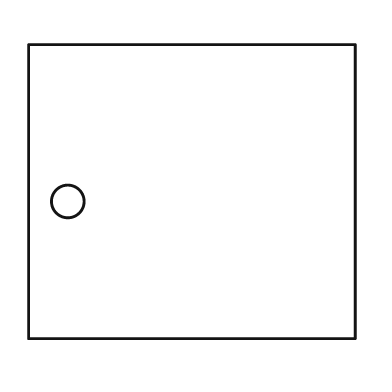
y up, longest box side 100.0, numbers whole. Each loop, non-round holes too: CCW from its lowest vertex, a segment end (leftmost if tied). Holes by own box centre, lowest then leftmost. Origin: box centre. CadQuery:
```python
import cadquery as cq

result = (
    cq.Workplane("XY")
    .moveTo(-50.0, -45.0)
    .lineTo(50.0, -45.0)
    .lineTo(50.0, 45.0)
    .lineTo(-50.0, 45.0)
    .close()
    .moveTo(-38.0, -3.0)
    .circle(5.0)
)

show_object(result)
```